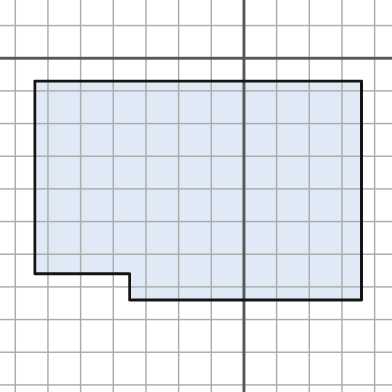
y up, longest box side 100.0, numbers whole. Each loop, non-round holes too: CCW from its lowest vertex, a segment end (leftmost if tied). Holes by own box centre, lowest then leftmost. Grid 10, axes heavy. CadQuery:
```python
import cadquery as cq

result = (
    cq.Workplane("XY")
    .moveTo(-35.0, -74.0)
    .lineTo(36.0, -74.0)
    .lineTo(36.0, -7.0)
    .lineTo(-64.0, -7.0)
    .lineTo(-64.0, -66.0)
    .lineTo(-35.0, -66.0)
    .close()
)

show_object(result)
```